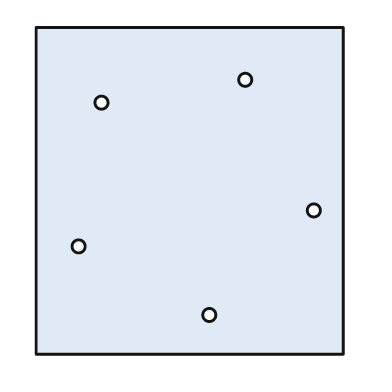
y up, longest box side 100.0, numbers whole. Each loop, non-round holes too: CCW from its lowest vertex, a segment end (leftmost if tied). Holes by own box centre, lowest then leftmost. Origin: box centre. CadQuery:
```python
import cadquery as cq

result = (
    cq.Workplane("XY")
    .moveTo(-47.0, -50.0)
    .lineTo(47.0, -50.0)
    .lineTo(47.0, 50.0)
    .lineTo(-47.0, 50.0)
    .close()
    .moveTo(6.0, -38.0)
    .circle(2.0)
    .moveTo(-34.0, -17.0)
    .circle(2.0)
    .moveTo(38.0, -6.0)
    .circle(2.0)
    .moveTo(-27.0, 27.0)
    .circle(2.0)
    .moveTo(17.0, 34.0)
    .circle(2.0)
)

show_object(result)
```